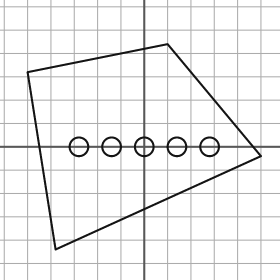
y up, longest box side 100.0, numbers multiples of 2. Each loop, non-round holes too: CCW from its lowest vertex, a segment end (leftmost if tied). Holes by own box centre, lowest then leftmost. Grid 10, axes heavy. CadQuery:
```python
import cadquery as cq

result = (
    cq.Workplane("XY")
    .moveTo(-38.0, -44.0)
    .lineTo(50.0, -4.0)
    .lineTo(10.0, 44.0)
    .lineTo(-50.0, 32.0)
    .close()
    .moveTo(-28.0, 0.0)
    .circle(4.0)
    .moveTo(-14.0, 0.0)
    .circle(4.0)
    .moveTo(0.0, 0.0)
    .circle(4.0)
    .moveTo(14.0, 0.0)
    .circle(4.0)
    .moveTo(28.0, 0.0)
    .circle(4.0)
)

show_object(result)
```